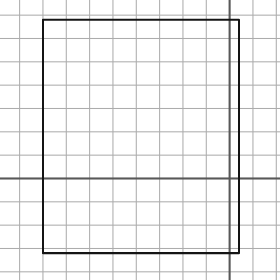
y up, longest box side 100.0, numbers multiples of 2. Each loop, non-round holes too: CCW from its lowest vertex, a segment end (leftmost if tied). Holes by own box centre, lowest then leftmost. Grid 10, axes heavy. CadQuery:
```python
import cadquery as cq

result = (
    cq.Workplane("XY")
    .moveTo(-80.0, -32.0)
    .lineTo(4.0, -32.0)
    .lineTo(4.0, 68.0)
    .lineTo(-80.0, 68.0)
    .close()
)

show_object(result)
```